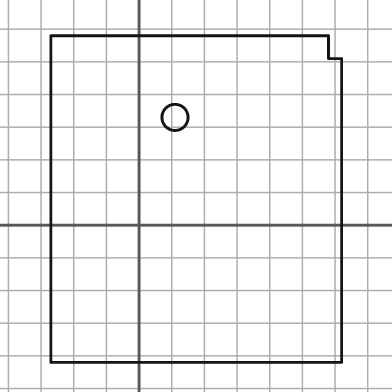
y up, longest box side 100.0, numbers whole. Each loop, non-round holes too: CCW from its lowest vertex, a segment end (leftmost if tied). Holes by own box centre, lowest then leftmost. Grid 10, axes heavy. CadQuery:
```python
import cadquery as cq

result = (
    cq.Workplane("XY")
    .moveTo(-27.0, -42.0)
    .lineTo(62.0, -42.0)
    .lineTo(62.0, 51.0)
    .lineTo(58.0, 51.0)
    .lineTo(58.0, 58.0)
    .lineTo(-27.0, 58.0)
    .close()
    .moveTo(11.0, 33.0)
    .circle(4.0)
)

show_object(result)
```